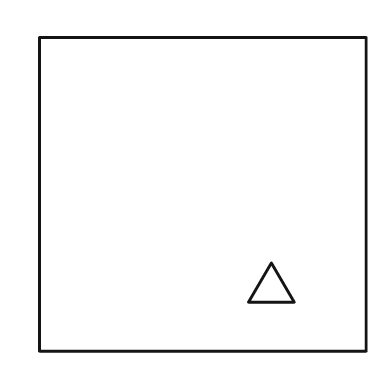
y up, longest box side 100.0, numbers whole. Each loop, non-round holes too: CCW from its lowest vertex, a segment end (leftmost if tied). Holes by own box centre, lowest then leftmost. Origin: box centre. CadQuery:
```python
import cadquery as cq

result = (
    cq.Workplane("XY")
    .moveTo(-50.0, -48.0)
    .lineTo(50.0, -48.0)
    .lineTo(50.0, 48.0)
    .lineTo(-50.0, 48.0)
    .close()
    .moveTo(14.0, -33.0)
    .lineTo(28.0, -33.0)
    .lineTo(21.0, -21.0)
    .close()
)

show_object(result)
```